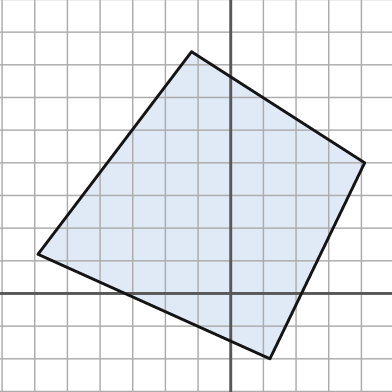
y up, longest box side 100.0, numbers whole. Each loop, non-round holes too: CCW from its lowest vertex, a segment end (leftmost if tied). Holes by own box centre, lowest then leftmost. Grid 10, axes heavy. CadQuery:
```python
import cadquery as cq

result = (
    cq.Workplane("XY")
    .moveTo(12.0, -20.0)
    .lineTo(41.0, 40.0)
    .lineTo(-12.0, 74.0)
    .lineTo(-59.0, 12.0)
    .close()
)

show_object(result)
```